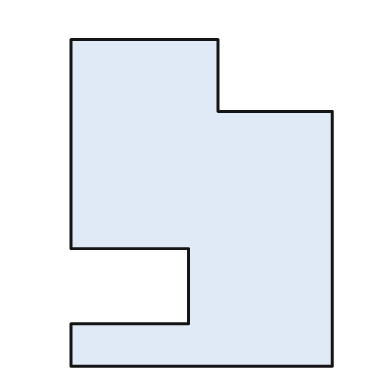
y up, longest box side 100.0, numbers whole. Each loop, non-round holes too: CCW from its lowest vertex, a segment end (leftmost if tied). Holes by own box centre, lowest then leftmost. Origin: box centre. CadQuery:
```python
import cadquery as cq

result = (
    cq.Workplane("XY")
    .moveTo(-40.0, -50.0)
    .lineTo(40.0, -50.0)
    .lineTo(40.0, 28.0)
    .lineTo(5.0, 28.0)
    .lineTo(5.0, 50.0)
    .lineTo(-40.0, 50.0)
    .lineTo(-40.0, -14.0)
    .lineTo(-4.0, -14.0)
    .lineTo(-4.0, -37.0)
    .lineTo(-40.0, -37.0)
    .close()
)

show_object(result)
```